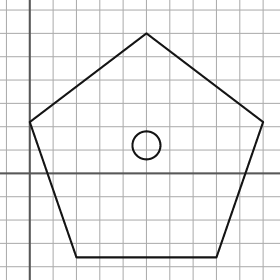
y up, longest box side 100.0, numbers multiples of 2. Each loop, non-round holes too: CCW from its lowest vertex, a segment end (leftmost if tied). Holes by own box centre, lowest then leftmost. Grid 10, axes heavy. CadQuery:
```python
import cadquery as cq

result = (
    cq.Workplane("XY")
    .moveTo(20.0, -36.0)
    .lineTo(80.0, -36.0)
    .lineTo(100.0, 22.0)
    .lineTo(50.0, 60.0)
    .lineTo(0.0, 22.0)
    .close()
    .moveTo(50.0, 12.0)
    .circle(6.0)
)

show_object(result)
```